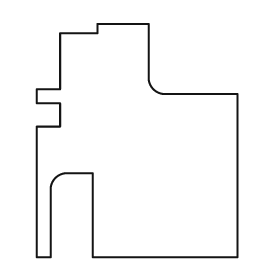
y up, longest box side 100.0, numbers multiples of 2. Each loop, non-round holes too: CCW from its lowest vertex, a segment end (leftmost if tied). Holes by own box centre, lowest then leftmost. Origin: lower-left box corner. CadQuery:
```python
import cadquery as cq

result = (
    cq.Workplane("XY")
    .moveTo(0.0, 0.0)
    .lineTo(6.0, 0.0)
    .lineTo(6.0, 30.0)
    .threePointArc((8.0, 34.0), (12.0, 36.0))
    .lineTo(24.0, 36.0)
    .lineTo(24.0, 0.0)
    .lineTo(86.0, 0.0)
    .lineTo(86.0, 70.0)
    .lineTo(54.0, 70.0)
    .threePointArc((50.0, 72.0), (48.0, 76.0))
    .lineTo(48.0, 100.0)
    .lineTo(26.0, 100.0)
    .lineTo(26.0, 96.0)
    .lineTo(10.0, 96.0)
    .lineTo(10.0, 72.0)
    .lineTo(0.0, 72.0)
    .lineTo(0.0, 66.0)
    .lineTo(10.0, 66.0)
    .lineTo(10.0, 56.0)
    .lineTo(0.0, 56.0)
    .close()
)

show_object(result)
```